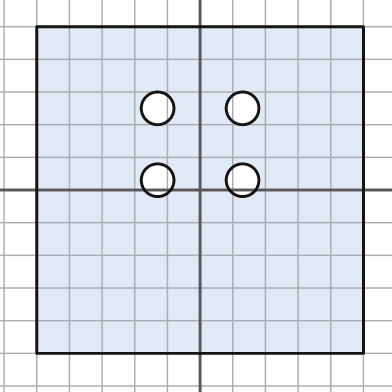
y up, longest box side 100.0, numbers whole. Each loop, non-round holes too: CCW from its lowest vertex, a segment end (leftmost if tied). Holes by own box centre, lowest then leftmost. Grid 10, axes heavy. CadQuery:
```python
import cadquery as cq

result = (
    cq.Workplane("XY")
    .moveTo(-50.0, -50.0)
    .lineTo(50.0, -50.0)
    .lineTo(50.0, 50.0)
    .lineTo(-50.0, 50.0)
    .close()
    .moveTo(-13.0, 3.0)
    .circle(5.0)
    .moveTo(13.0, 3.0)
    .circle(5.0)
    .moveTo(-13.0, 25.0)
    .circle(5.0)
    .moveTo(13.0, 25.0)
    .circle(5.0)
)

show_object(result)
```